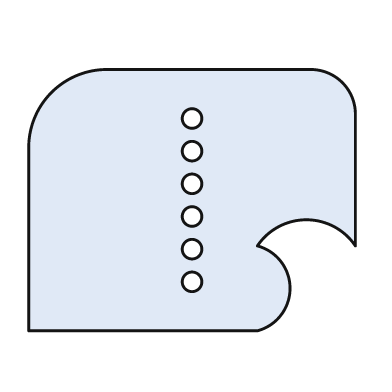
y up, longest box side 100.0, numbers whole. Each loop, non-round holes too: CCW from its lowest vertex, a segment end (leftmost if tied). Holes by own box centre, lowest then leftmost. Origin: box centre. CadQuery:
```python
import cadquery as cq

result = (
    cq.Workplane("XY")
    .moveTo(-50.0, -40.0)
    .lineTo(20.0, -40.0)
    .threePointArc((30.0, -27.0), (20.0, -14.0))
    .threePointArc((35.0, -6.0), (50.0, -14.0))
    .lineTo(50.0, 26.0)
    .threePointArc((46.0, 36.0), (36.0, 40.0))
    .lineTo(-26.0, 40.0)
    .threePointArc((-43.0, 33.0), (-50.0, 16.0))
    .close()
    .moveTo(0.0, -25.0)
    .circle(3.0)
    .moveTo(0.0, -15.0)
    .circle(3.0)
    .moveTo(0.0, -5.0)
    .circle(3.0)
    .moveTo(0.0, 5.0)
    .circle(3.0)
    .moveTo(0.0, 15.0)
    .circle(3.0)
    .moveTo(0.0, 25.0)
    .circle(3.0)
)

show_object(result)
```